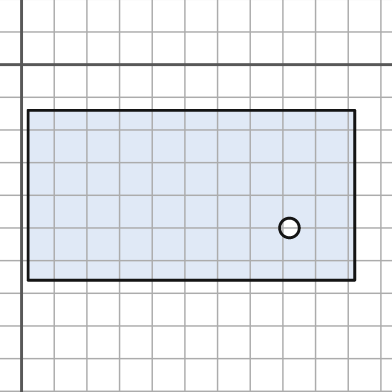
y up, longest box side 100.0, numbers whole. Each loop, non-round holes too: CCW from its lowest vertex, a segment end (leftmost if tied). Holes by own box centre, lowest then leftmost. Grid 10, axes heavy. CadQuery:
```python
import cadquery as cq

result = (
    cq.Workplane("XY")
    .moveTo(2.0, -66.0)
    .lineTo(102.0, -66.0)
    .lineTo(102.0, -14.0)
    .lineTo(2.0, -14.0)
    .close()
    .moveTo(82.0, -50.0)
    .circle(3.0)
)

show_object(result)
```